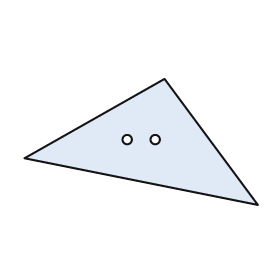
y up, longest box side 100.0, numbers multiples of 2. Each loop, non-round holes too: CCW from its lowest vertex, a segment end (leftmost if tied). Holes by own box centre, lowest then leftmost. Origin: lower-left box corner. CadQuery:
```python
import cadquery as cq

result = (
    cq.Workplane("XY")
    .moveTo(100.0, 0.0)
    .lineTo(60.0, 54.0)
    .lineTo(0.0, 20.0)
    .close()
    .moveTo(44.0, 28.0)
    .circle(2.0)
    .moveTo(56.0, 28.0)
    .circle(2.0)
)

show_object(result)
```